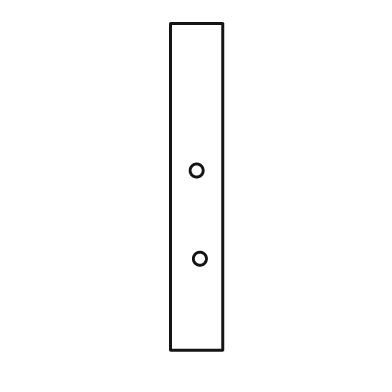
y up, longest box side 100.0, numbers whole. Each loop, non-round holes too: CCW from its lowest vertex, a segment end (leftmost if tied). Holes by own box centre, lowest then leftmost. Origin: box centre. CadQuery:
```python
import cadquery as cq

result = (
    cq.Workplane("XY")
    .moveTo(-8.0, -50.0)
    .lineTo(8.0, -50.0)
    .lineTo(8.0, 50.0)
    .lineTo(-8.0, 50.0)
    .close()
    .moveTo(1.0, -22.0)
    .circle(2.0)
    .moveTo(0.0, 5.0)
    .circle(2.0)
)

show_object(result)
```